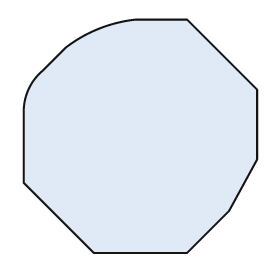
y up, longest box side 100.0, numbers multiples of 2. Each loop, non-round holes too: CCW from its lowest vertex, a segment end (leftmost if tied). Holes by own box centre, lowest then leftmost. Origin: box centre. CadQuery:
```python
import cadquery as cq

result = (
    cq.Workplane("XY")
    .moveTo(-20.0, -50.0)
    .lineTo(20.0, -50.0)
    .lineTo(38.0, -32.0)
    .lineTo(50.0, -10.0)
    .lineTo(50.0, 20.0)
    .lineTo(20.0, 50.0)
    .lineTo(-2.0, 50.0)
    .threePointArc((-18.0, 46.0), (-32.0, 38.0))
    .lineTo(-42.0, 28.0)
    .threePointArc((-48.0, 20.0), (-50.0, 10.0))
    .lineTo(-50.0, -20.0)
    .close()
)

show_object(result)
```